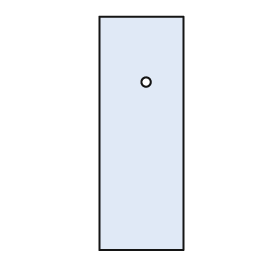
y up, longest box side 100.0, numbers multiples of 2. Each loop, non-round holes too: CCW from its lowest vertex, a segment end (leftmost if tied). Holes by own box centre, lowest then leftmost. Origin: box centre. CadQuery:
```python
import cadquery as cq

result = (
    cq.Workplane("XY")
    .moveTo(-18.0, -50.0)
    .lineTo(18.0, -50.0)
    .lineTo(18.0, 50.0)
    .lineTo(-18.0, 50.0)
    .close()
    .moveTo(2.0, 22.0)
    .circle(2.0)
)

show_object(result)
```